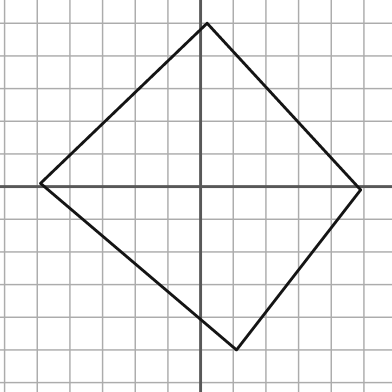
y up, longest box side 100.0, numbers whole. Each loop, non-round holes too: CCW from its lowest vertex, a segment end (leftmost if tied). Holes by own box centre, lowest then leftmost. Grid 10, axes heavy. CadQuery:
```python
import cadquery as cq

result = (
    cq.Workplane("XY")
    .moveTo(11.0, -50.0)
    .lineTo(49.0, -1.0)
    .lineTo(2.0, 50.0)
    .lineTo(-49.0, 1.0)
    .close()
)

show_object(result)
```